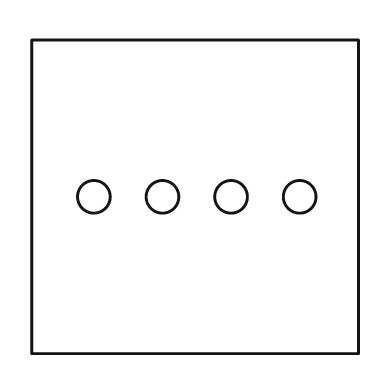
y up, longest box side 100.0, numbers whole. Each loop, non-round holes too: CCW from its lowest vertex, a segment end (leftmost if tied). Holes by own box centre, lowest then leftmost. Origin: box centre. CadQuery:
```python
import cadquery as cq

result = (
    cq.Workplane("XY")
    .moveTo(-50.0, -48.0)
    .lineTo(50.0, -48.0)
    .lineTo(50.0, 48.0)
    .lineTo(-50.0, 48.0)
    .close()
    .moveTo(-31.0, 0.0)
    .circle(5.0)
    .moveTo(-10.0, 0.0)
    .circle(5.0)
    .moveTo(11.0, 0.0)
    .circle(5.0)
    .moveTo(32.0, 0.0)
    .circle(5.0)
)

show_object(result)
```